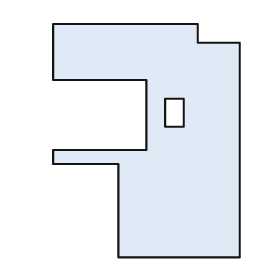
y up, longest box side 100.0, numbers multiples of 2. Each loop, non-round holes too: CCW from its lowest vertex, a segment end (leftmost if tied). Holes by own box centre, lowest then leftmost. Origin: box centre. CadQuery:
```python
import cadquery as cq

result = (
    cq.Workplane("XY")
    .moveTo(-12.0, -50.0)
    .lineTo(40.0, -50.0)
    .lineTo(40.0, 42.0)
    .lineTo(22.0, 42.0)
    .lineTo(22.0, 50.0)
    .lineTo(-40.0, 50.0)
    .lineTo(-40.0, 26.0)
    .lineTo(0.0, 26.0)
    .lineTo(0.0, -4.0)
    .lineTo(-40.0, -4.0)
    .lineTo(-40.0, -10.0)
    .lineTo(-12.0, -10.0)
    .close()
    .moveTo(8.0, 6.0)
    .lineTo(16.0, 6.0)
    .lineTo(16.0, 18.0)
    .lineTo(8.0, 18.0)
    .close()
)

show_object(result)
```